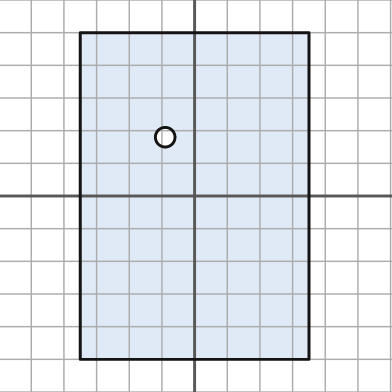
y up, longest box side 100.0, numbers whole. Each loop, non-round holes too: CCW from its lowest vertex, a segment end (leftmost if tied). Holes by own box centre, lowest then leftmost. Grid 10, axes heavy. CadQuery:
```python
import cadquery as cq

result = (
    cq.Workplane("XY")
    .moveTo(-35.0, -50.0)
    .lineTo(35.0, -50.0)
    .lineTo(35.0, 50.0)
    .lineTo(-35.0, 50.0)
    .close()
    .moveTo(-9.0, 18.0)
    .circle(3.0)
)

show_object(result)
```